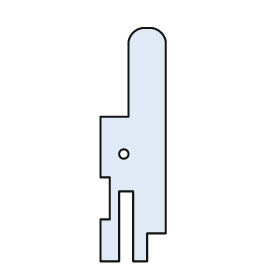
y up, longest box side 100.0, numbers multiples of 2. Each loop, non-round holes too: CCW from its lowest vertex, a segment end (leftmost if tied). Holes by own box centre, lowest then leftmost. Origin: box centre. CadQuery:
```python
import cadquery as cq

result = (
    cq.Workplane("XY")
    .moveTo(-14.0, -50.0)
    .lineTo(-6.0, -50.0)
    .lineTo(-6.0, -20.0)
    .lineTo(0.0, -20.0)
    .lineTo(0.0, -50.0)
    .lineTo(6.0, -50.0)
    .lineTo(6.0, -38.0)
    .lineTo(14.0, -38.0)
    .lineTo(14.0, 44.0)
    .threePointArc((12.0, 48.0), (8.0, 50.0))
    .lineTo(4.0, 50.0)
    .threePointArc((0.0, 48.0), (-2.0, 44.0))
    .lineTo(-2.0, 12.0)
    .lineTo(-14.0, 12.0)
    .lineTo(-14.0, -14.0)
    .lineTo(-10.0, -14.0)
    .lineTo(-10.0, -32.0)
    .lineTo(-14.0, -32.0)
    .close()
    .moveTo(-4.0, -4.0)
    .circle(2.0)
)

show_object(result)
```